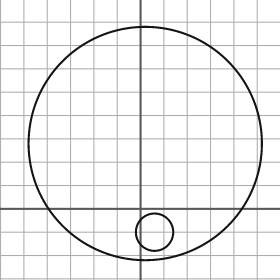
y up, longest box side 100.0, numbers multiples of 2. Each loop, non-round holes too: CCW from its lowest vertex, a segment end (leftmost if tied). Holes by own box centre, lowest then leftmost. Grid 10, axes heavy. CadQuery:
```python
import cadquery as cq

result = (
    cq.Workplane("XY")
    .moveTo(2.0, 28.0)
    .circle(50.0)
    .moveTo(6.0, -10.0)
    .circle(8.0)
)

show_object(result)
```